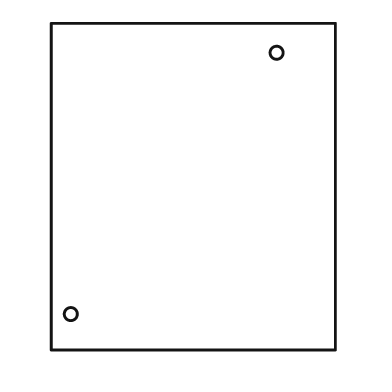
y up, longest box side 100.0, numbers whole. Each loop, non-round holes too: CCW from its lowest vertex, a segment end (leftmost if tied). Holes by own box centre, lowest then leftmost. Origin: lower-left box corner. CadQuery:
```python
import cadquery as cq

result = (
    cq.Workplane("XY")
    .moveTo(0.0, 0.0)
    .lineTo(87.0, 0.0)
    .lineTo(87.0, 100.0)
    .lineTo(0.0, 100.0)
    .close()
    .moveTo(6.0, 11.0)
    .circle(2.0)
    .moveTo(69.0, 91.0)
    .circle(2.0)
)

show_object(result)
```